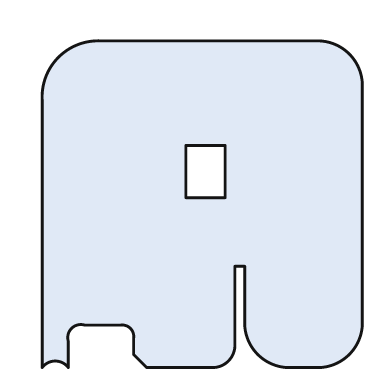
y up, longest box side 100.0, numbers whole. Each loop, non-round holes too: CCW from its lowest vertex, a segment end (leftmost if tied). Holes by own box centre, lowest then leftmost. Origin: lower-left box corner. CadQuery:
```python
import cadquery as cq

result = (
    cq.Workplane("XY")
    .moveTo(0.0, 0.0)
    .threePointArc((4.0, 2.0), (8.0, 0.0))
    .lineTo(8.0, 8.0)
    .threePointArc((9.0, 12.0), (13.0, 13.0))
    .lineTo(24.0, 13.0)
    .threePointArc((27.0, 12.0), (28.0, 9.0))
    .lineTo(28.0, 4.0)
    .lineTo(32.0, 0.0)
    .lineTo(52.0, 0.0)
    .threePointArc((57.0, 2.0), (59.0, 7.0))
    .lineTo(59.0, 31.0)
    .lineTo(62.0, 31.0)
    .lineTo(62.0, 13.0)
    .threePointArc((66.0, 4.0), (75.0, 0.0))
    .lineTo(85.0, 0.0)
    .threePointArc((94.0, 4.0), (98.0, 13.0))
    .lineTo(98.0, 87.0)
    .threePointArc((94.0, 96.0), (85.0, 100.0))
    .lineTo(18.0, 100.0)
    .threePointArc((5.0, 95.0), (0.0, 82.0))
    .close()
    .moveTo(44.0, 52.0)
    .lineTo(56.0, 52.0)
    .lineTo(56.0, 68.0)
    .lineTo(44.0, 68.0)
    .close()
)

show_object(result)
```